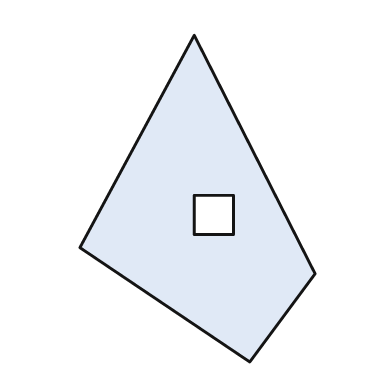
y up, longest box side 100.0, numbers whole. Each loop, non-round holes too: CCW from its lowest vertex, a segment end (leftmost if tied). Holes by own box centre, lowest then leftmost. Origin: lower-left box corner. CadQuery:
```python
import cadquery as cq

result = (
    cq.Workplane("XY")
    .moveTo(52.0, 0.0)
    .lineTo(72.0, 27.0)
    .lineTo(35.0, 100.0)
    .lineTo(0.0, 35.0)
    .close()
    .moveTo(35.0, 39.0)
    .lineTo(47.0, 39.0)
    .lineTo(47.0, 51.0)
    .lineTo(35.0, 51.0)
    .close()
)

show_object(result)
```